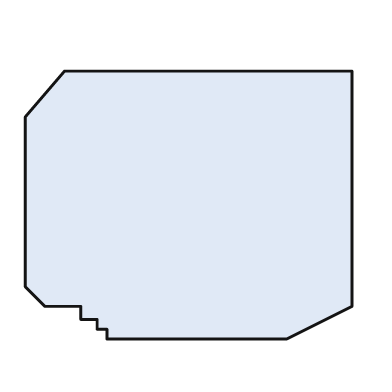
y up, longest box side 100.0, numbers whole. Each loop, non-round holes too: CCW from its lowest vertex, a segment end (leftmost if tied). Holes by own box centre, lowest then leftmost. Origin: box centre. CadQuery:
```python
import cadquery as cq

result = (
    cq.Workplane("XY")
    .moveTo(-25.0, -41.0)
    .lineTo(30.0, -41.0)
    .lineTo(50.0, -31.0)
    .lineTo(50.0, 41.0)
    .lineTo(-38.0, 41.0)
    .lineTo(-50.0, 27.0)
    .lineTo(-50.0, -25.0)
    .lineTo(-44.0, -31.0)
    .lineTo(-33.0, -31.0)
    .lineTo(-33.0, -35.0)
    .lineTo(-28.0, -35.0)
    .lineTo(-28.0, -38.0)
    .lineTo(-25.0, -38.0)
    .close()
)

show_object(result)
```